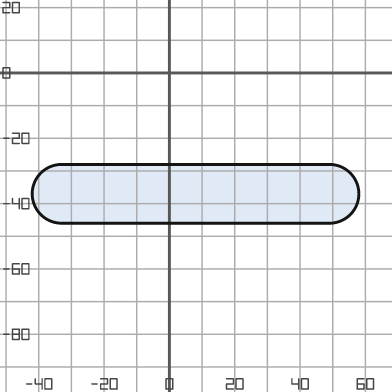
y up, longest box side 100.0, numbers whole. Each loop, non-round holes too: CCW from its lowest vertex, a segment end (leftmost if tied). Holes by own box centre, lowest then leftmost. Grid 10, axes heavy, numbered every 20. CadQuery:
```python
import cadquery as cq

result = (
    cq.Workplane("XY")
    .moveTo(-33.0, -46.0)
    .lineTo(49.0, -46.0)
    .threePointArc((58.0, -37.0), (49.0, -28.0))
    .lineTo(-33.0, -28.0)
    .threePointArc((-42.0, -37.0), (-33.0, -46.0))
    .close()
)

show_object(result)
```